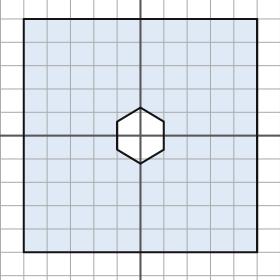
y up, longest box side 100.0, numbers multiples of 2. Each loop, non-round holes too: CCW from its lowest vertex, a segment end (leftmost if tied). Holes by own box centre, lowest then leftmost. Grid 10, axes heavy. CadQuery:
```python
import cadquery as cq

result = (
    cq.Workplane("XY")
    .moveTo(-50.0, -50.0)
    .lineTo(50.0, -50.0)
    .lineTo(50.0, 50.0)
    .lineTo(-50.0, 50.0)
    .close()
    .moveTo(0.0, -12.0)
    .lineTo(10.0, -6.0)
    .lineTo(10.0, 6.0)
    .lineTo(0.0, 12.0)
    .lineTo(-10.0, 6.0)
    .lineTo(-10.0, -6.0)
    .close()
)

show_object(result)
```